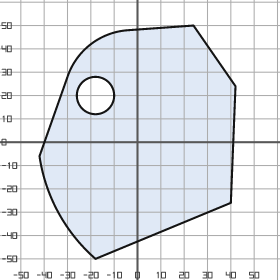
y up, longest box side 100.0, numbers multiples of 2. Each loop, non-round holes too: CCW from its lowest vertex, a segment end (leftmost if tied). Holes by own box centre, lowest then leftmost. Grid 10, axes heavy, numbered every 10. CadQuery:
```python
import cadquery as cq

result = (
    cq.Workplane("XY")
    .moveTo(-18.0, -50.0)
    .lineTo(40.0, -26.0)
    .lineTo(42.0, 24.0)
    .lineTo(24.0, 50.0)
    .lineTo(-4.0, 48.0)
    .threePointArc((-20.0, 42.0), (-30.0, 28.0))
    .lineTo(-42.0, -6.0)
    .threePointArc((-34.0, -30.0), (-18.0, -50.0))
    .close()
    .moveTo(-18.0, 20.0)
    .circle(8.0)
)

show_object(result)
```